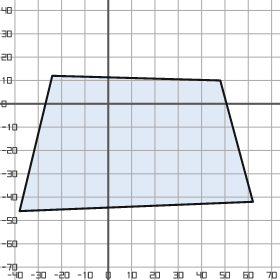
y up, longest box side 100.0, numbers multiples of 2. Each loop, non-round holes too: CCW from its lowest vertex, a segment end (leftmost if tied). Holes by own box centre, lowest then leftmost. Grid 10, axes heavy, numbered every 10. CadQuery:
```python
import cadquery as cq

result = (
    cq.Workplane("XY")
    .moveTo(-38.0, -46.0)
    .lineTo(62.0, -42.0)
    .lineTo(48.0, 10.0)
    .lineTo(-24.0, 12.0)
    .close()
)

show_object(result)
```